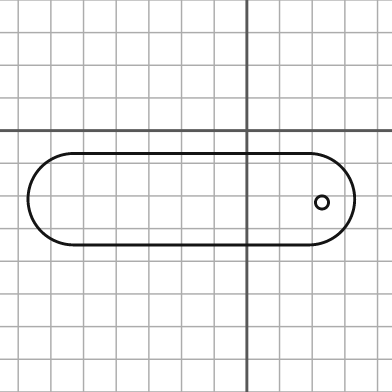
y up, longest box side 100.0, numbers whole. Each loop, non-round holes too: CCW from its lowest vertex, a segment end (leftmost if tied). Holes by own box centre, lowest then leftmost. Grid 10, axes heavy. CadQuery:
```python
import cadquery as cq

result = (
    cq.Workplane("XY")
    .moveTo(-53.0, -35.0)
    .lineTo(19.0, -35.0)
    .threePointArc((33.0, -21.0), (19.0, -7.0))
    .lineTo(-53.0, -7.0)
    .threePointArc((-67.0, -21.0), (-53.0, -35.0))
    .close()
    .moveTo(23.0, -22.0)
    .circle(2.0)
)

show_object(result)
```